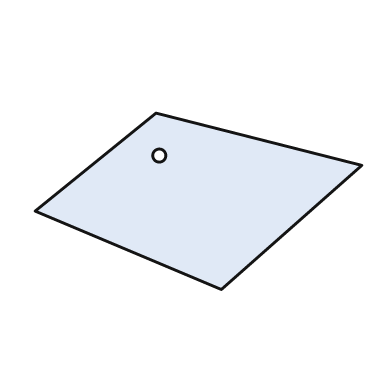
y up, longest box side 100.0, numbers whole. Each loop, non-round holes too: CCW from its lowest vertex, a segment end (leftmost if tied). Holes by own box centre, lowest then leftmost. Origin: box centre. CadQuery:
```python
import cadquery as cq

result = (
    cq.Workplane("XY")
    .moveTo(7.0, -27.0)
    .lineTo(50.0, 11.0)
    .lineTo(-13.0, 27.0)
    .lineTo(-50.0, -3.0)
    .close()
    .moveTo(-12.0, 14.0)
    .circle(2.0)
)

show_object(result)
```